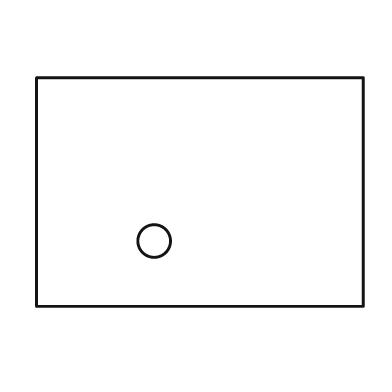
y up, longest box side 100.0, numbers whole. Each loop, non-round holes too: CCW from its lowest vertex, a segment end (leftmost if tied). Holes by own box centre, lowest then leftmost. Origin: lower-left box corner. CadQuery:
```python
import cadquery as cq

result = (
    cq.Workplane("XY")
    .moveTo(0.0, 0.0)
    .lineTo(100.0, 0.0)
    .lineTo(100.0, 70.0)
    .lineTo(0.0, 70.0)
    .close()
    .moveTo(36.0, 20.0)
    .circle(5.0)
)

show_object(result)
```